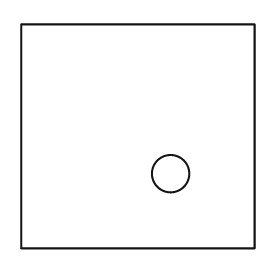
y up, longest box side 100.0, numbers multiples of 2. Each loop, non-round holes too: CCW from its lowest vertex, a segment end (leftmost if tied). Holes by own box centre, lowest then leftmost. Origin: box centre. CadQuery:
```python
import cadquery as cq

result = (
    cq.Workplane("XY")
    .moveTo(-50.0, -48.0)
    .lineTo(50.0, -48.0)
    .lineTo(50.0, 48.0)
    .lineTo(-50.0, 48.0)
    .close()
    .moveTo(14.0, -16.0)
    .circle(8.0)
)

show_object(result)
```